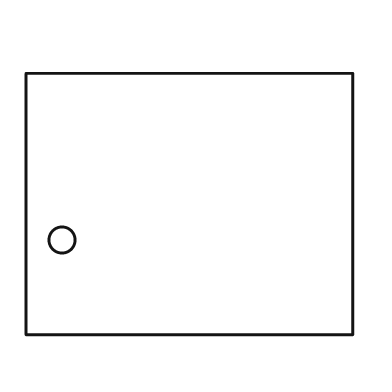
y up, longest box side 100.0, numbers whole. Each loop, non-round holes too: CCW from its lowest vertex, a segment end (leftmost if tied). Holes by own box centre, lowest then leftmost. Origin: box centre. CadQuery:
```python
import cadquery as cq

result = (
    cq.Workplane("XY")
    .moveTo(-50.0, -40.0)
    .lineTo(50.0, -40.0)
    .lineTo(50.0, 40.0)
    .lineTo(-50.0, 40.0)
    .close()
    .moveTo(-39.0, -11.0)
    .circle(4.0)
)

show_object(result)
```